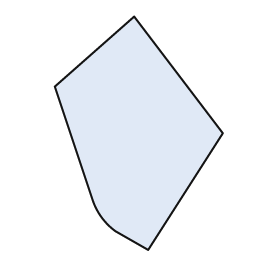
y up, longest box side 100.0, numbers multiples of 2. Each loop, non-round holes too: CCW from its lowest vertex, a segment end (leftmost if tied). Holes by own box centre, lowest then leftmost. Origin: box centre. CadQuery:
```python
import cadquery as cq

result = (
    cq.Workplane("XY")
    .moveTo(4.0, -50.0)
    .lineTo(36.0, 0.0)
    .lineTo(-2.0, 50.0)
    .lineTo(-36.0, 20.0)
    .lineTo(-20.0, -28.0)
    .threePointArc((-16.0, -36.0), (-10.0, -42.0))
    .close()
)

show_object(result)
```